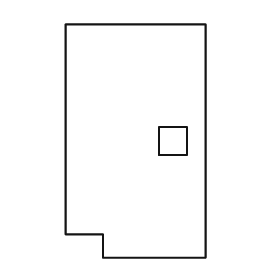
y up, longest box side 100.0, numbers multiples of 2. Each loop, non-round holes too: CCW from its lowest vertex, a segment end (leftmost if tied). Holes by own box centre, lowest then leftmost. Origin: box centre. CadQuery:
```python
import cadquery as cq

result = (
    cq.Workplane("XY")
    .moveTo(-14.0, -50.0)
    .lineTo(30.0, -50.0)
    .lineTo(30.0, 50.0)
    .lineTo(-30.0, 50.0)
    .lineTo(-30.0, -40.0)
    .lineTo(-14.0, -40.0)
    .close()
    .moveTo(10.0, -6.0)
    .lineTo(22.0, -6.0)
    .lineTo(22.0, 6.0)
    .lineTo(10.0, 6.0)
    .close()
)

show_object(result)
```